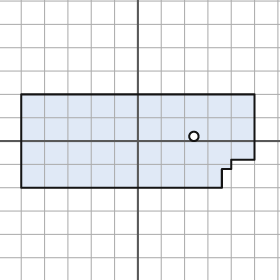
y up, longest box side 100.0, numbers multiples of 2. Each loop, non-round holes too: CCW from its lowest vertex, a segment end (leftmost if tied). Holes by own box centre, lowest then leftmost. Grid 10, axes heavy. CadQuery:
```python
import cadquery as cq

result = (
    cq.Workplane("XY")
    .moveTo(-50.0, -20.0)
    .lineTo(36.0, -20.0)
    .lineTo(36.0, -12.0)
    .lineTo(40.0, -12.0)
    .lineTo(40.0, -8.0)
    .lineTo(50.0, -8.0)
    .lineTo(50.0, 20.0)
    .lineTo(-50.0, 20.0)
    .close()
    .moveTo(24.0, 2.0)
    .circle(2.0)
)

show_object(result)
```